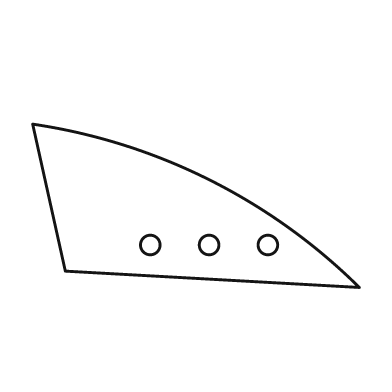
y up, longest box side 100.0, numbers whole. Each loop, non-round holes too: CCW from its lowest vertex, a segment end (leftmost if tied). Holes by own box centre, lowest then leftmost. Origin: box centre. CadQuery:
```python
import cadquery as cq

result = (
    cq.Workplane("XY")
    .moveTo(50.0, -25.0)
    .threePointArc((4.0, 8.0), (-50.0, 25.0))
    .lineTo(-40.0, -20.0)
    .close()
    .moveTo(-14.0, -12.0)
    .circle(3.0)
    .moveTo(4.0, -12.0)
    .circle(3.0)
    .moveTo(22.0, -12.0)
    .circle(3.0)
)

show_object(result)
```